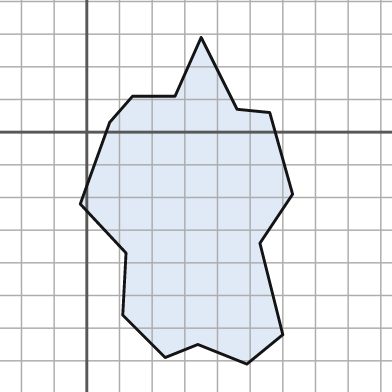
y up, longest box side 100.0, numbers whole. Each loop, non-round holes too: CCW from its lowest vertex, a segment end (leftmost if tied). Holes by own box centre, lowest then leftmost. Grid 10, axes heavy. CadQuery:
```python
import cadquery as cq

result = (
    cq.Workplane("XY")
    .moveTo(49.0, -71.0)
    .lineTo(60.0, -62.0)
    .lineTo(53.0, -34.0)
    .lineTo(63.0, -19.0)
    .lineTo(56.0, 6.0)
    .lineTo(46.0, 7.0)
    .lineTo(35.0, 29.0)
    .lineTo(27.0, 11.0)
    .lineTo(14.0, 11.0)
    .lineTo(7.0, 3.0)
    .lineTo(-2.0, -22.0)
    .lineTo(12.0, -37.0)
    .lineTo(11.0, -56.0)
    .lineTo(24.0, -69.0)
    .lineTo(34.0, -65.0)
    .close()
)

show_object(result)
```